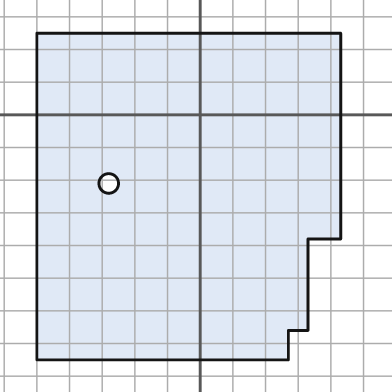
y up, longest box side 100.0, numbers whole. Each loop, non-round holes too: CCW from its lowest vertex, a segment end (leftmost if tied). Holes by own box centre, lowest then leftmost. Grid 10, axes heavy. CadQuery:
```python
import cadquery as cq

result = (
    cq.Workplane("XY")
    .moveTo(-50.0, -75.0)
    .lineTo(27.0, -75.0)
    .lineTo(27.0, -66.0)
    .lineTo(33.0, -66.0)
    .lineTo(33.0, -38.0)
    .lineTo(43.0, -38.0)
    .lineTo(43.0, 25.0)
    .lineTo(-50.0, 25.0)
    .close()
    .moveTo(-28.0, -21.0)
    .circle(3.0)
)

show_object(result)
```